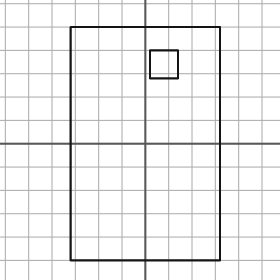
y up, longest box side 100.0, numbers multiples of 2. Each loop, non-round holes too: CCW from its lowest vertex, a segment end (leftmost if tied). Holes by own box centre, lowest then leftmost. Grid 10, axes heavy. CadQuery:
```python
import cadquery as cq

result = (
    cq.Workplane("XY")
    .moveTo(-32.0, -50.0)
    .lineTo(32.0, -50.0)
    .lineTo(32.0, 50.0)
    .lineTo(-32.0, 50.0)
    .close()
    .moveTo(2.0, 28.0)
    .lineTo(14.0, 28.0)
    .lineTo(14.0, 40.0)
    .lineTo(2.0, 40.0)
    .close()
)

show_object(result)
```